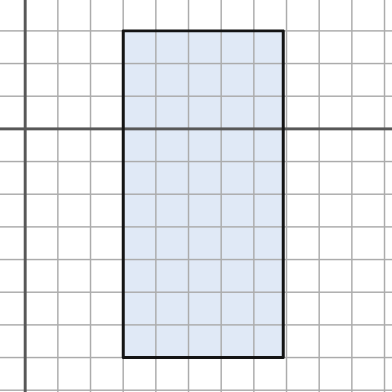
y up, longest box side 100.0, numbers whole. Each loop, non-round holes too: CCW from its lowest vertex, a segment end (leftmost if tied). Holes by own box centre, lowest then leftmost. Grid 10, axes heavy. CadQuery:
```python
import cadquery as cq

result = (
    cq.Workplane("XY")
    .moveTo(30.0, -70.0)
    .lineTo(79.0, -70.0)
    .lineTo(79.0, 30.0)
    .lineTo(30.0, 30.0)
    .close()
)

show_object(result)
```